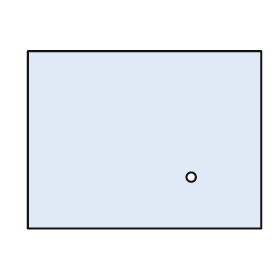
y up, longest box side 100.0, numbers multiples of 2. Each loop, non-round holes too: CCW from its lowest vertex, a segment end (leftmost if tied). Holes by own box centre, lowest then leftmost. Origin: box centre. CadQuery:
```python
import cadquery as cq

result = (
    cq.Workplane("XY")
    .moveTo(-50.0, -38.0)
    .lineTo(50.0, -38.0)
    .lineTo(50.0, 38.0)
    .lineTo(-50.0, 38.0)
    .close()
    .moveTo(20.0, -16.0)
    .circle(2.0)
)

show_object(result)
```